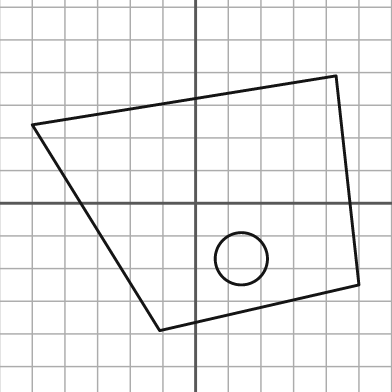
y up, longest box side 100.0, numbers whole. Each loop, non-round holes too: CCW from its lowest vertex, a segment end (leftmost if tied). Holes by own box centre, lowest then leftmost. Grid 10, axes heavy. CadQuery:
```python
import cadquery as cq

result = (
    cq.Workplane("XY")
    .moveTo(-11.0, -39.0)
    .lineTo(50.0, -25.0)
    .lineTo(43.0, 39.0)
    .lineTo(-50.0, 24.0)
    .close()
    .moveTo(14.0, -17.0)
    .circle(8.0)
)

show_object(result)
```